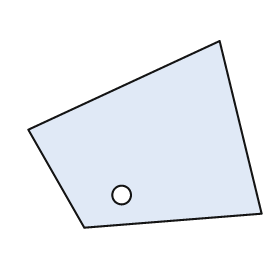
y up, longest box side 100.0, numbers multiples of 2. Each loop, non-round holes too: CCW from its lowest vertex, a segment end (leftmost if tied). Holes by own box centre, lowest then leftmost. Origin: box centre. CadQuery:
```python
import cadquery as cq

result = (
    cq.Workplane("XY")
    .moveTo(-26.0, -40.0)
    .lineTo(50.0, -34.0)
    .lineTo(32.0, 40.0)
    .lineTo(-50.0, 2.0)
    .close()
    .moveTo(-10.0, -26.0)
    .circle(4.0)
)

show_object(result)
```